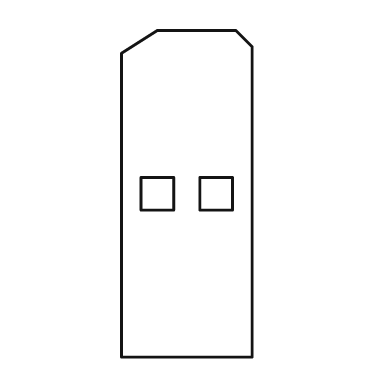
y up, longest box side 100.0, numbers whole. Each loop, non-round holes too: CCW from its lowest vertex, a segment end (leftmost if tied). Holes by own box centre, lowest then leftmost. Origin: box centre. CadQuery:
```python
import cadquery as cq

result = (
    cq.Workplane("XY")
    .moveTo(-20.0, -50.0)
    .lineTo(20.0, -50.0)
    .lineTo(20.0, 45.0)
    .lineTo(15.0, 50.0)
    .lineTo(-9.0, 50.0)
    .lineTo(-20.0, 43.0)
    .close()
    .moveTo(-14.0, -5.0)
    .lineTo(-4.0, -5.0)
    .lineTo(-4.0, 5.0)
    .lineTo(-14.0, 5.0)
    .close()
    .moveTo(4.0, -5.0)
    .lineTo(14.0, -5.0)
    .lineTo(14.0, 5.0)
    .lineTo(4.0, 5.0)
    .close()
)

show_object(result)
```